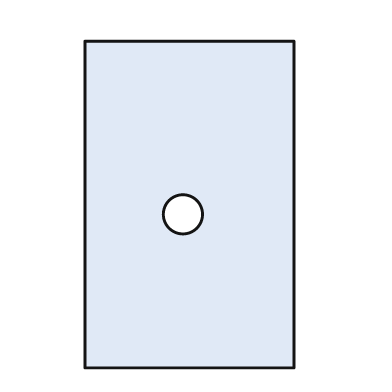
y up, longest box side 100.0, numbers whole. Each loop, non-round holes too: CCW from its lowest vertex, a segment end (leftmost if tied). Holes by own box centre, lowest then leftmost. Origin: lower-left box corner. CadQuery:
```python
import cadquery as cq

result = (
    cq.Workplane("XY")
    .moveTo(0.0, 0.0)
    .lineTo(64.0, 0.0)
    .lineTo(64.0, 100.0)
    .lineTo(0.0, 100.0)
    .close()
    .moveTo(30.0, 47.0)
    .circle(6.0)
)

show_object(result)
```